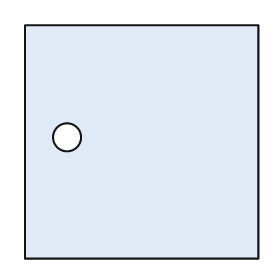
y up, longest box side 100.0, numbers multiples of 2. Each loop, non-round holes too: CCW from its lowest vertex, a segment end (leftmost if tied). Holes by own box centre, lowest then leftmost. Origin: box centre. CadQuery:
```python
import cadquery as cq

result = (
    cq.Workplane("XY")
    .moveTo(-50.0, -50.0)
    .lineTo(50.0, -50.0)
    .lineTo(50.0, 50.0)
    .lineTo(-50.0, 50.0)
    .close()
    .moveTo(-32.0, 2.0)
    .circle(6.0)
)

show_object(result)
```